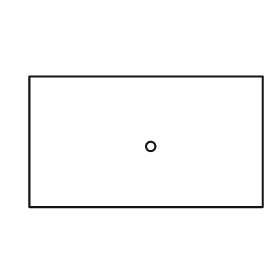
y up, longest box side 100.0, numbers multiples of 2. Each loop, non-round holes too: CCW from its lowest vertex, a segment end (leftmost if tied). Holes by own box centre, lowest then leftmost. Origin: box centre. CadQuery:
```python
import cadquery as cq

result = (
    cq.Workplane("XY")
    .moveTo(-50.0, -28.0)
    .lineTo(50.0, -28.0)
    .lineTo(50.0, 28.0)
    .lineTo(-50.0, 28.0)
    .close()
    .moveTo(2.0, -2.0)
    .circle(2.0)
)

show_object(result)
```